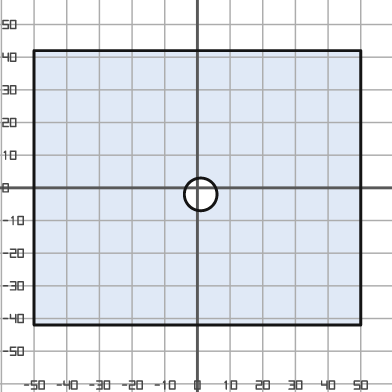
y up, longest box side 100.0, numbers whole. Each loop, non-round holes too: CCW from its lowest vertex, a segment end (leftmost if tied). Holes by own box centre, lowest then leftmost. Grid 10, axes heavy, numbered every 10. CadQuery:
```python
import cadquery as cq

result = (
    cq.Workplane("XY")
    .moveTo(-50.0, -42.0)
    .lineTo(50.0, -42.0)
    .lineTo(50.0, 42.0)
    .lineTo(-50.0, 42.0)
    .close()
    .moveTo(1.0, -2.0)
    .circle(5.0)
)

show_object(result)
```